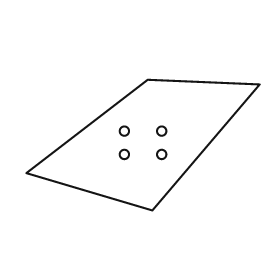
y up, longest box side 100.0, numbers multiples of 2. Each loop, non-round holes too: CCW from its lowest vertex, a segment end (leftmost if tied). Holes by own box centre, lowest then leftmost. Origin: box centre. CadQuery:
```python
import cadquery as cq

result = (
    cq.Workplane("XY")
    .moveTo(4.0, -28.0)
    .lineTo(50.0, 26.0)
    .lineTo(2.0, 28.0)
    .lineTo(-50.0, -12.0)
    .close()
    .moveTo(-8.0, -4.0)
    .circle(2.0)
    .moveTo(8.0, -4.0)
    .circle(2.0)
    .moveTo(-8.0, 6.0)
    .circle(2.0)
    .moveTo(8.0, 6.0)
    .circle(2.0)
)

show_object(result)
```